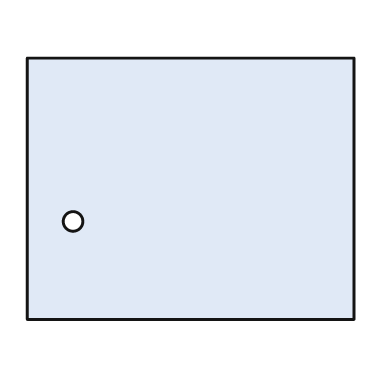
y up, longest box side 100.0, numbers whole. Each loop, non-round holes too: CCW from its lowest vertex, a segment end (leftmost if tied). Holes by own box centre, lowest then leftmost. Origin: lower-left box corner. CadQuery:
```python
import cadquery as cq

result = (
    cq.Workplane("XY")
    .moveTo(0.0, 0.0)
    .lineTo(100.0, 0.0)
    .lineTo(100.0, 80.0)
    .lineTo(0.0, 80.0)
    .close()
    .moveTo(14.0, 30.0)
    .circle(3.0)
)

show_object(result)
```